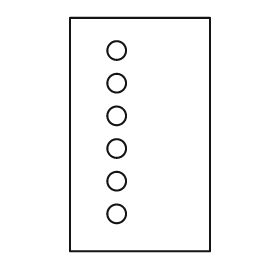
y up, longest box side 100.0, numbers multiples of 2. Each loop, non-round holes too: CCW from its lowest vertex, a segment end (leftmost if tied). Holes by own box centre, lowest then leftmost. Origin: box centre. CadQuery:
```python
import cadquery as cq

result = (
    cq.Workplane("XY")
    .moveTo(-30.0, -50.0)
    .lineTo(30.0, -50.0)
    .lineTo(30.0, 50.0)
    .lineTo(-30.0, 50.0)
    .close()
    .moveTo(-10.0, -34.0)
    .circle(4.0)
    .moveTo(-10.0, -20.0)
    .circle(4.0)
    .moveTo(-10.0, -6.0)
    .circle(4.0)
    .moveTo(-10.0, 8.0)
    .circle(4.0)
    .moveTo(-10.0, 22.0)
    .circle(4.0)
    .moveTo(-10.0, 36.0)
    .circle(4.0)
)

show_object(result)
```